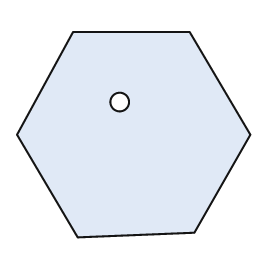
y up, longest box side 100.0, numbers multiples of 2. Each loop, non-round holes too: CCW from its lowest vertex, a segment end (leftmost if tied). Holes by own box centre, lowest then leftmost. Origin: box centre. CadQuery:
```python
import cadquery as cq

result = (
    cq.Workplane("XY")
    .moveTo(-24.0, -44.0)
    .lineTo(26.0, -42.0)
    .lineTo(50.0, 0.0)
    .lineTo(24.0, 44.0)
    .lineTo(-26.0, 44.0)
    .lineTo(-50.0, 0.0)
    .close()
    .moveTo(-6.0, 14.0)
    .circle(4.0)
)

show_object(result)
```